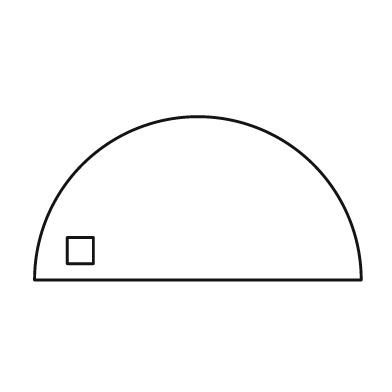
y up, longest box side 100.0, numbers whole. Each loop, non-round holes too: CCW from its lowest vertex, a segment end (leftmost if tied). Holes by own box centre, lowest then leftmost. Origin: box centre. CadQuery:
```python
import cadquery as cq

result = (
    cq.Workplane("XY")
    .moveTo(-50.0, -25.0)
    .lineTo(50.0, -25.0)
    .threePointArc((0.0, 25.0), (-50.0, -25.0))
    .close()
    .moveTo(-40.0, -20.0)
    .lineTo(-32.0, -20.0)
    .lineTo(-32.0, -12.0)
    .lineTo(-40.0, -12.0)
    .close()
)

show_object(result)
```